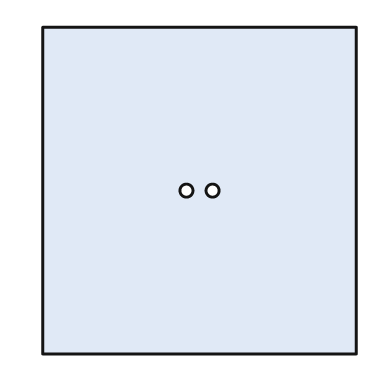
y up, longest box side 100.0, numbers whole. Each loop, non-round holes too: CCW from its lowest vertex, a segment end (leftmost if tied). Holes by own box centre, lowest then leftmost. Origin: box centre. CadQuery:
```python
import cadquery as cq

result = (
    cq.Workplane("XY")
    .moveTo(-48.0, -50.0)
    .lineTo(48.0, -50.0)
    .lineTo(48.0, 50.0)
    .lineTo(-48.0, 50.0)
    .close()
    .moveTo(-4.0, 0.0)
    .circle(2.0)
    .moveTo(4.0, 0.0)
    .circle(2.0)
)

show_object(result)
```